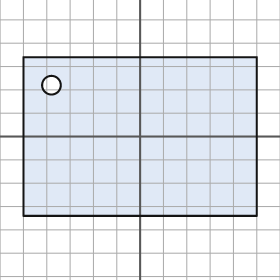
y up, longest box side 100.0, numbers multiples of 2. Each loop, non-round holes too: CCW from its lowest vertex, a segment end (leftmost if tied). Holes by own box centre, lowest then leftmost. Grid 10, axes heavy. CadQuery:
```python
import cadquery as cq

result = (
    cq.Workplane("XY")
    .moveTo(-50.0, -34.0)
    .lineTo(50.0, -34.0)
    .lineTo(50.0, 34.0)
    .lineTo(-50.0, 34.0)
    .close()
    .moveTo(-38.0, 22.0)
    .circle(4.0)
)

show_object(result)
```